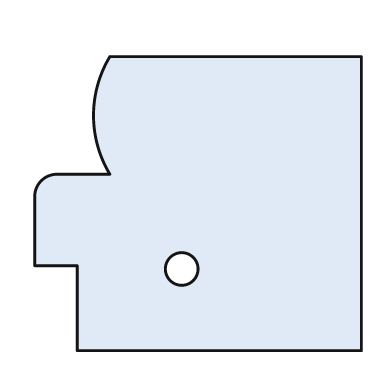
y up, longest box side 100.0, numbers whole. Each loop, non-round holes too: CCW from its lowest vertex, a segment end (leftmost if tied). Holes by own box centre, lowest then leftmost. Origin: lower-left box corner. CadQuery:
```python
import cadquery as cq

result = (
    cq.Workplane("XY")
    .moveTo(13.0, 0.0)
    .lineTo(100.0, 0.0)
    .lineTo(100.0, 90.0)
    .lineTo(23.0, 90.0)
    .threePointArc((18.0, 72.0), (23.0, 54.0))
    .lineTo(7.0, 54.0)
    .threePointArc((2.0, 52.0), (0.0, 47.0))
    .lineTo(0.0, 26.0)
    .lineTo(13.0, 26.0)
    .close()
    .moveTo(45.0, 25.0)
    .circle(5.0)
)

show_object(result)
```